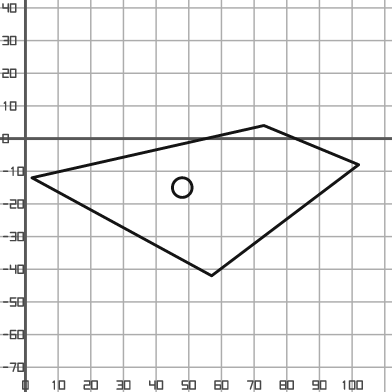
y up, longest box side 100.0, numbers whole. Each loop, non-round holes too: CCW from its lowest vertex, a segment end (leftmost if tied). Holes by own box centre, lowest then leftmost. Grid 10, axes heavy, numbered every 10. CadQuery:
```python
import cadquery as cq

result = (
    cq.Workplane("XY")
    .moveTo(57.0, -42.0)
    .lineTo(102.0, -8.0)
    .lineTo(73.0, 4.0)
    .lineTo(2.0, -12.0)
    .close()
    .moveTo(48.0, -15.0)
    .circle(3.0)
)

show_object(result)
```